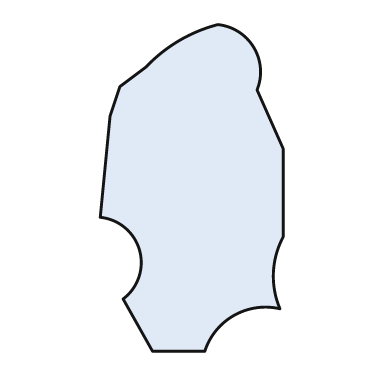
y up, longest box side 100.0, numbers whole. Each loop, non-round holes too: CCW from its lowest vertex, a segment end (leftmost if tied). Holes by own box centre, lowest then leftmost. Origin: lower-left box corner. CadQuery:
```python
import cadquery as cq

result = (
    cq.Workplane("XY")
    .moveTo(16.0, 0.0)
    .lineTo(32.0, 0.0)
    .threePointArc((41.0, 11.0), (55.0, 13.0))
    .threePointArc((53.0, 24.0), (56.0, 35.0))
    .lineTo(56.0, 62.0)
    .lineTo(48.0, 80.0)
    .threePointArc((47.0, 93.0), (36.0, 100.0))
    .threePointArc((24.0, 95.0), (14.0, 87.0))
    .lineTo(6.0, 81.0)
    .lineTo(3.0, 72.0)
    .lineTo(0.0, 41.0)
    .threePointArc((12.0, 31.0), (7.0, 16.0))
    .close()
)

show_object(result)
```